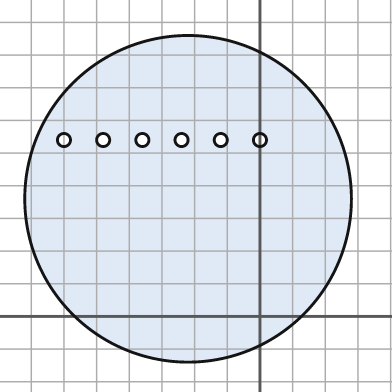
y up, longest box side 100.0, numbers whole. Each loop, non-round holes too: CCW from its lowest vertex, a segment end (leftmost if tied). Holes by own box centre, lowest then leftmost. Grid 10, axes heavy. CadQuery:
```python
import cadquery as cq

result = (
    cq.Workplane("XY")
    .moveTo(-22.0, 36.0)
    .circle(50.0)
    .moveTo(-60.0, 54.0)
    .circle(2.0)
    .moveTo(-48.0, 54.0)
    .circle(2.0)
    .moveTo(-36.0, 54.0)
    .circle(2.0)
    .moveTo(-24.0, 54.0)
    .circle(2.0)
    .moveTo(-12.0, 54.0)
    .circle(2.0)
    .moveTo(0.0, 54.0)
    .circle(2.0)
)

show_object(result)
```